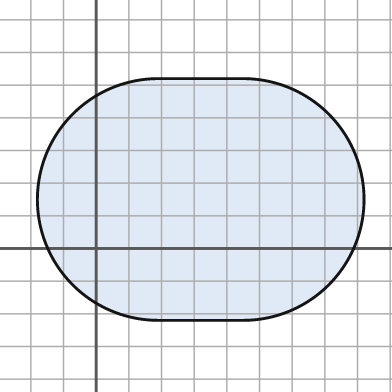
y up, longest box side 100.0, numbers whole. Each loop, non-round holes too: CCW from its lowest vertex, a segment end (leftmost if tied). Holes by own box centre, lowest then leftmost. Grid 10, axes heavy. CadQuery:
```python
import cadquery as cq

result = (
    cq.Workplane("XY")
    .moveTo(19.0, -22.0)
    .lineTo(45.0, -22.0)
    .threePointArc((82.0, 15.0), (45.0, 52.0))
    .lineTo(19.0, 52.0)
    .threePointArc((-18.0, 15.0), (19.0, -22.0))
    .close()
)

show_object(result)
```